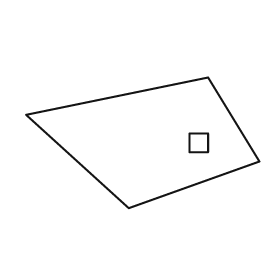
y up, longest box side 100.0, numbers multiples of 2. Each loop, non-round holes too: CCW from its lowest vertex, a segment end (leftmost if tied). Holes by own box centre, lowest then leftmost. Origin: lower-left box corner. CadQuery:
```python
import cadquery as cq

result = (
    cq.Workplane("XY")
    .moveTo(44.0, 0.0)
    .lineTo(100.0, 20.0)
    .lineTo(78.0, 56.0)
    .lineTo(0.0, 40.0)
    .close()
    .moveTo(70.0, 24.0)
    .lineTo(78.0, 24.0)
    .lineTo(78.0, 32.0)
    .lineTo(70.0, 32.0)
    .close()
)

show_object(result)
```